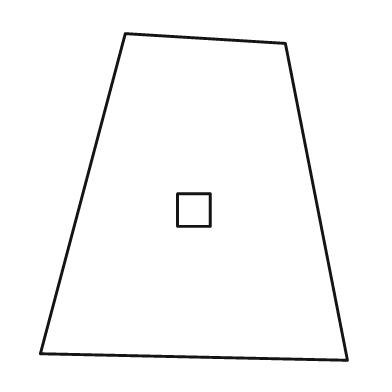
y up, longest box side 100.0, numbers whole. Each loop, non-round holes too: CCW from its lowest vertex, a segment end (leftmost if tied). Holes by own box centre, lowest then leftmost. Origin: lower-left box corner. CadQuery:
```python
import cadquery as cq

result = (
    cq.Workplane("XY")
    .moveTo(94.0, 0.0)
    .lineTo(75.0, 97.0)
    .lineTo(26.0, 100.0)
    .lineTo(0.0, 2.0)
    .close()
    .moveTo(42.0, 41.0)
    .lineTo(52.0, 41.0)
    .lineTo(52.0, 51.0)
    .lineTo(42.0, 51.0)
    .close()
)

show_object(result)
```